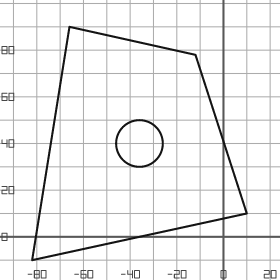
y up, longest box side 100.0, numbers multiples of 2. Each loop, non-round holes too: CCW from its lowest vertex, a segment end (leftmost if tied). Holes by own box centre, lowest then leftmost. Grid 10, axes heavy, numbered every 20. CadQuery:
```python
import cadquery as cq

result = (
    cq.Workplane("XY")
    .moveTo(-82.0, -10.0)
    .lineTo(10.0, 10.0)
    .lineTo(-12.0, 78.0)
    .lineTo(-66.0, 90.0)
    .close()
    .moveTo(-36.0, 40.0)
    .circle(10.0)
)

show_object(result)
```